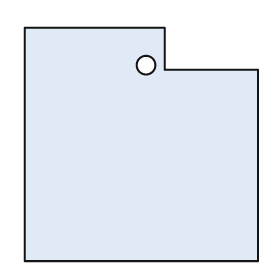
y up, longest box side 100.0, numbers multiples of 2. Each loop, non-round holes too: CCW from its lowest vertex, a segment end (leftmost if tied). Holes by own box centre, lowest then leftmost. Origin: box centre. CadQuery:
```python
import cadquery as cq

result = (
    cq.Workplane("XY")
    .moveTo(-50.0, -50.0)
    .lineTo(50.0, -50.0)
    .lineTo(50.0, 32.0)
    .lineTo(10.0, 32.0)
    .lineTo(10.0, 50.0)
    .lineTo(-50.0, 50.0)
    .close()
    .moveTo(2.0, 34.0)
    .circle(4.0)
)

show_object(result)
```